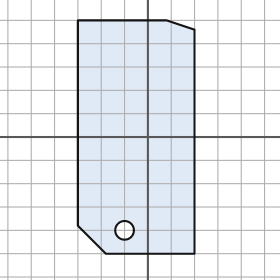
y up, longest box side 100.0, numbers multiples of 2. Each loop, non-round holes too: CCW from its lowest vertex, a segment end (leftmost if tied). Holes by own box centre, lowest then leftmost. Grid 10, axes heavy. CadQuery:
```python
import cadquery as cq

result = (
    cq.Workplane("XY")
    .moveTo(-18.0, -50.0)
    .lineTo(20.0, -50.0)
    .lineTo(20.0, 46.0)
    .lineTo(8.0, 50.0)
    .lineTo(-30.0, 50.0)
    .lineTo(-30.0, -38.0)
    .close()
    .moveTo(-10.0, -40.0)
    .circle(4.0)
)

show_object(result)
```